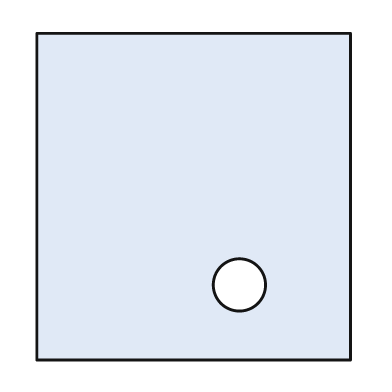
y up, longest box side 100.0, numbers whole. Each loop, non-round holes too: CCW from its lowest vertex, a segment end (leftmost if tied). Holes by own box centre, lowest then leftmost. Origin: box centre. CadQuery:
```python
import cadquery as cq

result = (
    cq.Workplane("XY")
    .moveTo(-48.0, -50.0)
    .lineTo(48.0, -50.0)
    .lineTo(48.0, 50.0)
    .lineTo(-48.0, 50.0)
    .close()
    .moveTo(14.0, -27.0)
    .circle(8.0)
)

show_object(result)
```